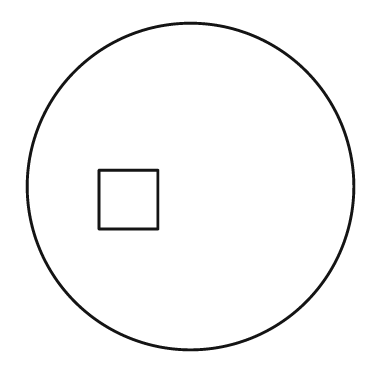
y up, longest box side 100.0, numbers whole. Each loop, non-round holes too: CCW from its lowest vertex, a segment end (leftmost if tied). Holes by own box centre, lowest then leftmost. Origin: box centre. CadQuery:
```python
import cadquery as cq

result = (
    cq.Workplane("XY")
    .moveTo(0.0, 0.0)
    .circle(50.0)
    .moveTo(-28.0, -13.0)
    .lineTo(-10.0, -13.0)
    .lineTo(-10.0, 5.0)
    .lineTo(-28.0, 5.0)
    .close()
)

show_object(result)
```